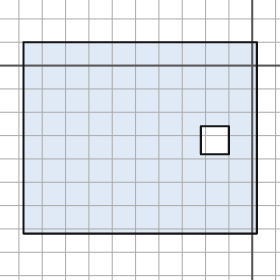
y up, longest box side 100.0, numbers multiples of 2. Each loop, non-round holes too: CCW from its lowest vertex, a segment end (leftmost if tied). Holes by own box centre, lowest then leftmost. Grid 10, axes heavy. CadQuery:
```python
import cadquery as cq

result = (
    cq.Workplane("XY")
    .moveTo(-98.0, -72.0)
    .lineTo(2.0, -72.0)
    .lineTo(2.0, 10.0)
    .lineTo(-98.0, 10.0)
    .close()
    .moveTo(-22.0, -38.0)
    .lineTo(-10.0, -38.0)
    .lineTo(-10.0, -26.0)
    .lineTo(-22.0, -26.0)
    .close()
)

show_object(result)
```